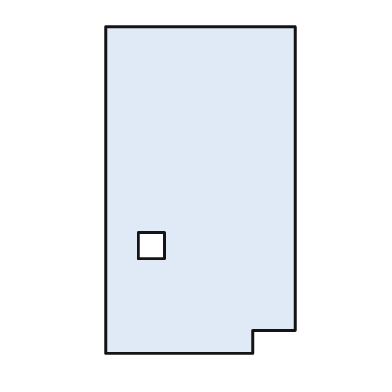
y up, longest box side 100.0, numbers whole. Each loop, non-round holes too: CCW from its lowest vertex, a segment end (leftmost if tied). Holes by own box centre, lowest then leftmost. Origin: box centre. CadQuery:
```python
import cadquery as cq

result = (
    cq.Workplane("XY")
    .moveTo(-29.0, -50.0)
    .lineTo(16.0, -50.0)
    .lineTo(16.0, -43.0)
    .lineTo(29.0, -43.0)
    .lineTo(29.0, 50.0)
    .lineTo(-29.0, 50.0)
    .close()
    .moveTo(-19.0, -21.0)
    .lineTo(-11.0, -21.0)
    .lineTo(-11.0, -13.0)
    .lineTo(-19.0, -13.0)
    .close()
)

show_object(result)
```